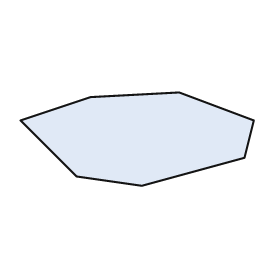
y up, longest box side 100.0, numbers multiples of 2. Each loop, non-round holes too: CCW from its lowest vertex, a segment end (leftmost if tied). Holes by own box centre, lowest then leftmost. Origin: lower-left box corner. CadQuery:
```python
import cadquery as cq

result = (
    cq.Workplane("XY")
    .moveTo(52.0, 0.0)
    .lineTo(96.0, 12.0)
    .lineTo(100.0, 28.0)
    .lineTo(68.0, 40.0)
    .lineTo(30.0, 38.0)
    .lineTo(0.0, 28.0)
    .lineTo(24.0, 4.0)
    .close()
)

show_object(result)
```